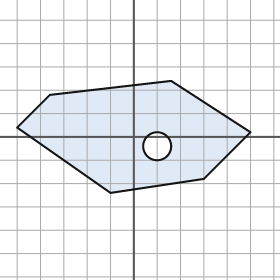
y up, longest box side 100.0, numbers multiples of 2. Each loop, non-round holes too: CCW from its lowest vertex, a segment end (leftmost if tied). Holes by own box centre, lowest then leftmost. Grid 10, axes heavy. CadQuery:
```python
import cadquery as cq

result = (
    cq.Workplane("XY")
    .moveTo(-10.0, -24.0)
    .lineTo(30.0, -18.0)
    .lineTo(50.0, 2.0)
    .lineTo(16.0, 24.0)
    .lineTo(-36.0, 18.0)
    .lineTo(-50.0, 4.0)
    .close()
    .moveTo(10.0, -4.0)
    .circle(6.0)
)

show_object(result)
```